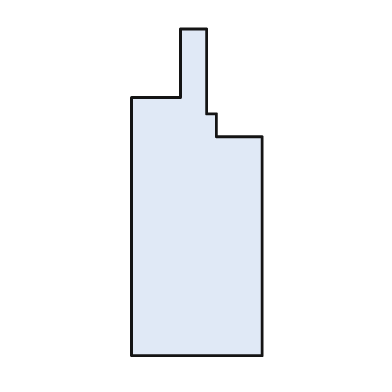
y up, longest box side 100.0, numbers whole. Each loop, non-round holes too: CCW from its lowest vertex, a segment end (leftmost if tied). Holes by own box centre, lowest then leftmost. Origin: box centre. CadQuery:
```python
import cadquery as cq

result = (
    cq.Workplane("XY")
    .moveTo(-20.0, -50.0)
    .lineTo(20.0, -50.0)
    .lineTo(20.0, 17.0)
    .lineTo(6.0, 17.0)
    .lineTo(6.0, 24.0)
    .lineTo(3.0, 24.0)
    .lineTo(3.0, 50.0)
    .lineTo(-5.0, 50.0)
    .lineTo(-5.0, 29.0)
    .lineTo(-20.0, 29.0)
    .close()
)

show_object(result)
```